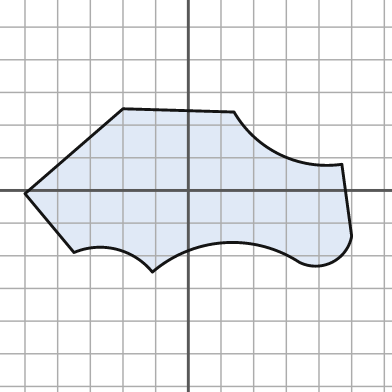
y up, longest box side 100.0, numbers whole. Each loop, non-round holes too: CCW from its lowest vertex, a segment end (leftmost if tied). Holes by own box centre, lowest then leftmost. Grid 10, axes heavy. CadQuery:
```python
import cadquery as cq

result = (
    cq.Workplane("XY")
    .moveTo(-11.0, -25.0)
    .threePointArc((11.0, -16.0), (34.0, -22.0))
    .threePointArc((44.0, -22.0), (50.0, -14.0))
    .lineTo(47.0, 8.0)
    .threePointArc((28.0, 11.0), (14.0, 24.0))
    .lineTo(-20.0, 25.0)
    .lineTo(-50.0, -1.0)
    .lineTo(-35.0, -19.0)
    .threePointArc((-22.0, -18.0), (-11.0, -25.0))
    .close()
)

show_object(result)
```